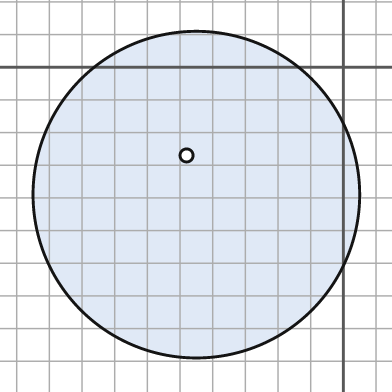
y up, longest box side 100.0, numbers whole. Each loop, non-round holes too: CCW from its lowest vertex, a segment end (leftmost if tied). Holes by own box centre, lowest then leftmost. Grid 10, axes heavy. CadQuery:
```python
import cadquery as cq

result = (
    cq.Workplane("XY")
    .moveTo(-45.0, -39.0)
    .circle(50.0)
    .moveTo(-48.0, -27.0)
    .circle(2.0)
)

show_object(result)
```